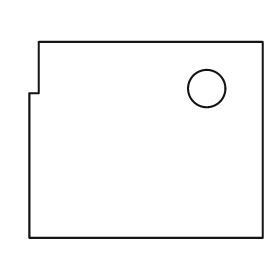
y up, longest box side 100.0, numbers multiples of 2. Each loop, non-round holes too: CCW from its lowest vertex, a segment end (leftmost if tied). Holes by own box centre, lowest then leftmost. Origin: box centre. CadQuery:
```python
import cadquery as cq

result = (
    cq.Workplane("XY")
    .moveTo(-50.0, -42.0)
    .lineTo(50.0, -42.0)
    .lineTo(50.0, 42.0)
    .lineTo(-46.0, 42.0)
    .lineTo(-46.0, 20.0)
    .lineTo(-50.0, 20.0)
    .close()
    .moveTo(26.0, 22.0)
    .circle(8.0)
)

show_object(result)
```